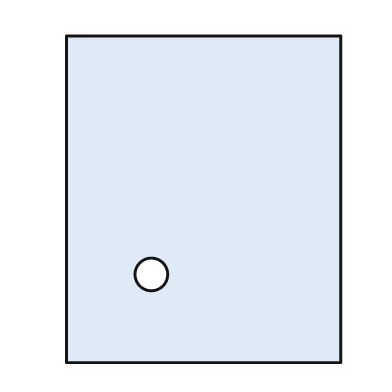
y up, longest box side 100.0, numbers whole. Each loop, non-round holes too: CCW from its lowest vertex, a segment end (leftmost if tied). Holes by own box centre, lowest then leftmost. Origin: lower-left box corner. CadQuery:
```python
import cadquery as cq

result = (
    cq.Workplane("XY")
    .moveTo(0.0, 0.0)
    .lineTo(84.0, 0.0)
    .lineTo(84.0, 100.0)
    .lineTo(0.0, 100.0)
    .close()
    .moveTo(26.0, 27.0)
    .circle(5.0)
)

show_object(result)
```